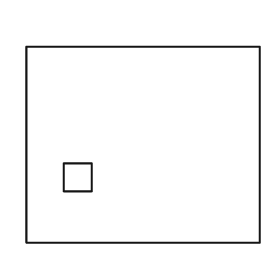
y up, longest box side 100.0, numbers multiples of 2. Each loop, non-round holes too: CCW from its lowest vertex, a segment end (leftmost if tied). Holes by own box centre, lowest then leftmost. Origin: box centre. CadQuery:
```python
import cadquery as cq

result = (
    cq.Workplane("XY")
    .moveTo(-50.0, -42.0)
    .lineTo(50.0, -42.0)
    .lineTo(50.0, 42.0)
    .lineTo(-50.0, 42.0)
    .close()
    .moveTo(-34.0, -20.0)
    .lineTo(-22.0, -20.0)
    .lineTo(-22.0, -8.0)
    .lineTo(-34.0, -8.0)
    .close()
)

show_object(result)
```